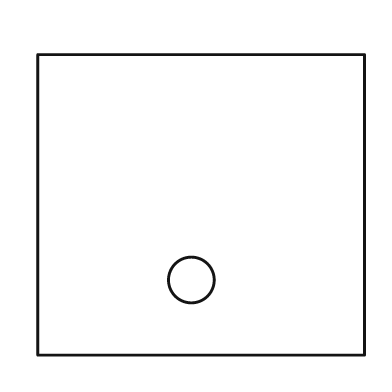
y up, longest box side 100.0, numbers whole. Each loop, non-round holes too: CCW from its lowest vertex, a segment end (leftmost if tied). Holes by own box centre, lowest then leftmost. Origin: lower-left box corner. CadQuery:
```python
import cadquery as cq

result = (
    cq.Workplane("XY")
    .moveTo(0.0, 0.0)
    .lineTo(100.0, 0.0)
    .lineTo(100.0, 92.0)
    .lineTo(0.0, 92.0)
    .close()
    .moveTo(47.0, 23.0)
    .circle(7.0)
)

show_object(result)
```